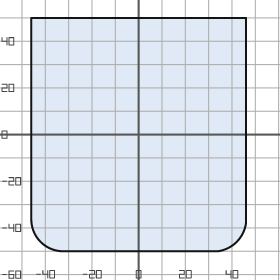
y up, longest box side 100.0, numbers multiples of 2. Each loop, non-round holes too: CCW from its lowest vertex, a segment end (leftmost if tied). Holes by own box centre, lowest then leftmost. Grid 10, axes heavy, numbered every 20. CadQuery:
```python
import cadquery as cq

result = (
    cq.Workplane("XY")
    .moveTo(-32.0, -50.0)
    .lineTo(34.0, -50.0)
    .threePointArc((42.0, -46.0), (46.0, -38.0))
    .lineTo(46.0, 50.0)
    .lineTo(-46.0, 50.0)
    .lineTo(-46.0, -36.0)
    .threePointArc((-42.0, -46.0), (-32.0, -50.0))
    .close()
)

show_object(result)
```